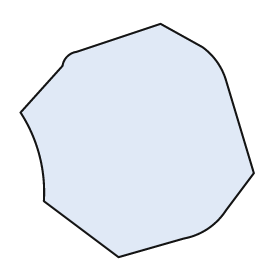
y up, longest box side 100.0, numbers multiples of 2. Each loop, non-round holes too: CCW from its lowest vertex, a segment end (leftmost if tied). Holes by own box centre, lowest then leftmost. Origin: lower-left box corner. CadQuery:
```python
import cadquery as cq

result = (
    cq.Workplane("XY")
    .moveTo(42.0, 0.0)
    .lineTo(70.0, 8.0)
    .threePointArc((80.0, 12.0), (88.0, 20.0))
    .lineTo(100.0, 36.0)
    .lineTo(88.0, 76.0)
    .threePointArc((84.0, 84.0), (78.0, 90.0))
    .lineTo(60.0, 100.0)
    .lineTo(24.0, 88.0)
    .threePointArc((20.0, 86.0), (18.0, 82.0))
    .lineTo(0.0, 62.0)
    .threePointArc((8.0, 44.0), (10.0, 24.0))
    .close()
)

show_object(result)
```